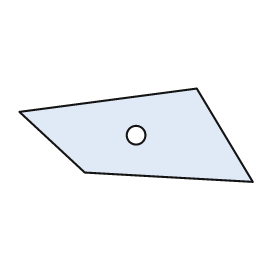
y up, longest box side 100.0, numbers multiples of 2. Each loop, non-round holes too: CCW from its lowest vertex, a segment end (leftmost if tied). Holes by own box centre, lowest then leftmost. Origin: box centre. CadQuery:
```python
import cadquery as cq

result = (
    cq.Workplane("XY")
    .moveTo(50.0, -20.0)
    .lineTo(26.0, 20.0)
    .lineTo(-50.0, 10.0)
    .lineTo(-22.0, -16.0)
    .close()
    .moveTo(0.0, 0.0)
    .circle(4.0)
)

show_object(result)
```